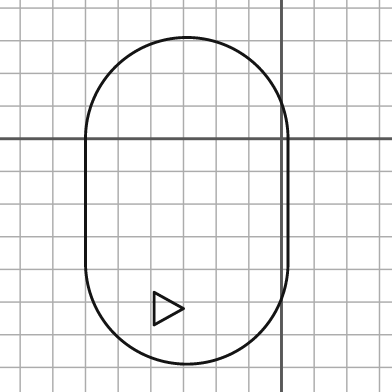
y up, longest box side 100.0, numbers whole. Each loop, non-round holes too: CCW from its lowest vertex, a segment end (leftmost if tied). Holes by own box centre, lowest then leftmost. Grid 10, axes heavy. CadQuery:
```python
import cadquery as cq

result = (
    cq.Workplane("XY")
    .moveTo(-60.0, -38.0)
    .threePointArc((-29.0, -69.0), (2.0, -38.0))
    .lineTo(2.0, 0.0)
    .threePointArc((-29.0, 31.0), (-60.0, 0.0))
    .close()
    .moveTo(-39.0, -57.0)
    .lineTo(-30.0, -52.0)
    .lineTo(-39.0, -47.0)
    .close()
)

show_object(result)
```